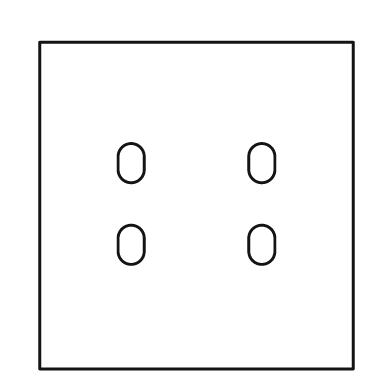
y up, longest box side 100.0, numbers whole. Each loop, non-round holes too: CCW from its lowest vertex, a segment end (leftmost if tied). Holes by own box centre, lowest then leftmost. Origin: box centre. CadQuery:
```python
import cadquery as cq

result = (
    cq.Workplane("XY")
    .moveTo(-48.0, -50.0)
    .lineTo(48.0, -50.0)
    .lineTo(48.0, 50.0)
    .lineTo(-48.0, 50.0)
    .close()
    .moveTo(-24.0, -14.0)
    .threePointArc((-20.0, -18.0), (-16.0, -14.0))
    .lineTo(-16.0, -10.0)
    .threePointArc((-20.0, -6.0), (-24.0, -10.0))
    .close()
    .moveTo(16.0, -14.0)
    .threePointArc((20.0, -18.0), (24.0, -14.0))
    .lineTo(24.0, -10.0)
    .threePointArc((20.0, -6.0), (16.0, -10.0))
    .close()
    .moveTo(-24.0, 11.0)
    .threePointArc((-20.0, 7.0), (-16.0, 11.0))
    .lineTo(-16.0, 15.0)
    .threePointArc((-20.0, 19.0), (-24.0, 15.0))
    .close()
    .moveTo(16.0, 11.0)
    .threePointArc((20.0, 7.0), (24.0, 11.0))
    .lineTo(24.0, 15.0)
    .threePointArc((20.0, 19.0), (16.0, 15.0))
    .close()
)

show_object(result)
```